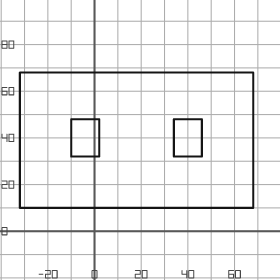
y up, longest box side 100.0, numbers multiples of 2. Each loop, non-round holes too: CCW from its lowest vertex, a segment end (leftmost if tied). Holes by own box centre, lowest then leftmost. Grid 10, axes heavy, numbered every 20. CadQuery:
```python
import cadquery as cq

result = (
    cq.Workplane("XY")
    .moveTo(-32.0, 10.0)
    .lineTo(68.0, 10.0)
    .lineTo(68.0, 68.0)
    .lineTo(-32.0, 68.0)
    .close()
    .moveTo(-10.0, 32.0)
    .lineTo(2.0, 32.0)
    .lineTo(2.0, 48.0)
    .lineTo(-10.0, 48.0)
    .close()
    .moveTo(34.0, 32.0)
    .lineTo(46.0, 32.0)
    .lineTo(46.0, 48.0)
    .lineTo(34.0, 48.0)
    .close()
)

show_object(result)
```